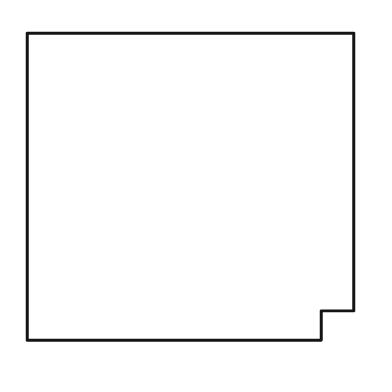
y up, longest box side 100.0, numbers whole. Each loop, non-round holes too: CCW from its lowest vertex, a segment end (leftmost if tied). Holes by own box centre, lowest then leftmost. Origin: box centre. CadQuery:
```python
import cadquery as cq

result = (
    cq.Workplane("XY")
    .moveTo(-50.0, -47.0)
    .lineTo(40.0, -47.0)
    .lineTo(40.0, -38.0)
    .lineTo(50.0, -38.0)
    .lineTo(50.0, 47.0)
    .lineTo(-50.0, 47.0)
    .close()
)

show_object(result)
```